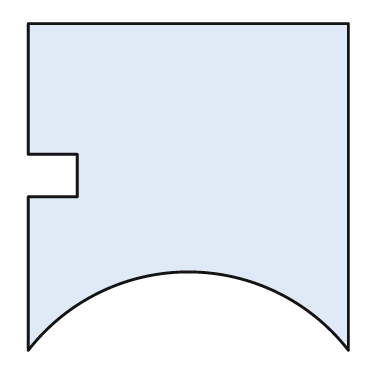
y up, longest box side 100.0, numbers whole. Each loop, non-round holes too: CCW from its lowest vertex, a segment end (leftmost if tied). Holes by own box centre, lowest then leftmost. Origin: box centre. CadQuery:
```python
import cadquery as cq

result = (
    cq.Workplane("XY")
    .moveTo(-49.0, -50.0)
    .threePointArc((0.0, -26.0), (49.0, -50.0))
    .lineTo(49.0, 50.0)
    .lineTo(-49.0, 50.0)
    .lineTo(-49.0, 10.0)
    .lineTo(-34.0, 10.0)
    .lineTo(-34.0, -3.0)
    .lineTo(-49.0, -3.0)
    .close()
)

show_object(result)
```